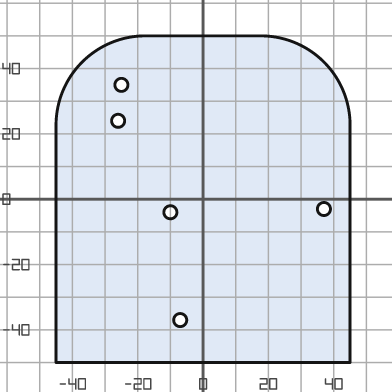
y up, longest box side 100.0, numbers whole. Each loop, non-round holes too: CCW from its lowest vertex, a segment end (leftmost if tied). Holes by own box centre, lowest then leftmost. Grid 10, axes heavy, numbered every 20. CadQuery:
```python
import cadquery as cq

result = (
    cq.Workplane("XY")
    .moveTo(-45.0, -50.0)
    .lineTo(45.0, -50.0)
    .lineTo(45.0, 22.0)
    .threePointArc((37.0, 42.0), (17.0, 50.0))
    .lineTo(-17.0, 50.0)
    .threePointArc((-37.0, 42.0), (-45.0, 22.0))
    .close()
    .moveTo(-7.0, -37.0)
    .circle(2.0)
    .moveTo(-10.0, -4.0)
    .circle(2.0)
    .moveTo(37.0, -3.0)
    .circle(2.0)
    .moveTo(-26.0, 24.0)
    .circle(2.0)
    .moveTo(-25.0, 35.0)
    .circle(2.0)
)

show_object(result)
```